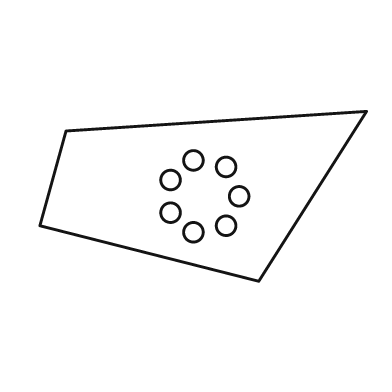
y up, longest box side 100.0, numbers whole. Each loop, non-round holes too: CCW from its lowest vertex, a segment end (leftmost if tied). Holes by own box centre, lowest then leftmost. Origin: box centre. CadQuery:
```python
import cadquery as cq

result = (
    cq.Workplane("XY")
    .moveTo(17.0, -26.0)
    .lineTo(50.0, 26.0)
    .lineTo(-42.0, 20.0)
    .lineTo(-50.0, -9.0)
    .close()
    .moveTo(-3.0, -11.0)
    .circle(3.0)
    .moveTo(7.0, -9.0)
    .circle(3.0)
    .moveTo(-10.0, -5.0)
    .circle(3.0)
    .moveTo(11.0, 0.0)
    .circle(3.0)
    .moveTo(-10.0, 5.0)
    .circle(3.0)
    .moveTo(7.0, 9.0)
    .circle(3.0)
    .moveTo(-3.0, 11.0)
    .circle(3.0)
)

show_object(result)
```